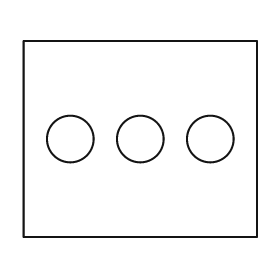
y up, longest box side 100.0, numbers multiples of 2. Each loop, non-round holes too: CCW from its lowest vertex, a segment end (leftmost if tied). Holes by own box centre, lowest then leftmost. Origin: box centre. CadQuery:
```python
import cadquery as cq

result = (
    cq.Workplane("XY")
    .moveTo(-50.0, -42.0)
    .lineTo(50.0, -42.0)
    .lineTo(50.0, 42.0)
    .lineTo(-50.0, 42.0)
    .close()
    .moveTo(-30.0, 0.0)
    .circle(10.0)
    .moveTo(0.0, 0.0)
    .circle(10.0)
    .moveTo(30.0, 0.0)
    .circle(10.0)
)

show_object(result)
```